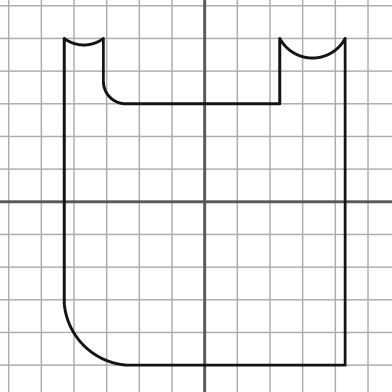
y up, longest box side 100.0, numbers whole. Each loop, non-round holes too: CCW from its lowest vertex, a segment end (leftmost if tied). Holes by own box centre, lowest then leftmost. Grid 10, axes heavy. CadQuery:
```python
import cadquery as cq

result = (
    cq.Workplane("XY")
    .moveTo(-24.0, -50.0)
    .lineTo(43.0, -50.0)
    .lineTo(43.0, 50.0)
    .threePointArc((33.0, 44.0), (23.0, 50.0))
    .lineTo(23.0, 30.0)
    .lineTo(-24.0, 30.0)
    .threePointArc((-29.0, 32.0), (-31.0, 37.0))
    .lineTo(-31.0, 50.0)
    .threePointArc((-37.0, 48.0), (-43.0, 50.0))
    .lineTo(-43.0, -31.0)
    .threePointArc((-37.0, -44.0), (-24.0, -50.0))
    .close()
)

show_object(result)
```